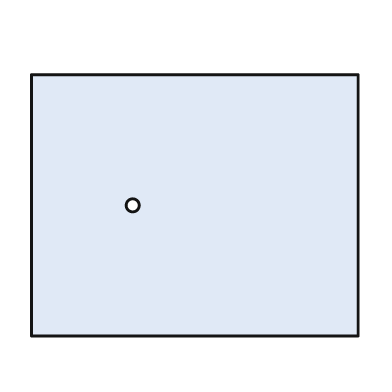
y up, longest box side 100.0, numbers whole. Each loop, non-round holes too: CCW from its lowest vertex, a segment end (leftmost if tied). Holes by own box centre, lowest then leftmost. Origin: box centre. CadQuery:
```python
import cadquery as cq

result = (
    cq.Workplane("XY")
    .moveTo(-50.0, -40.0)
    .lineTo(50.0, -40.0)
    .lineTo(50.0, 40.0)
    .lineTo(-50.0, 40.0)
    .close()
    .moveTo(-19.0, 0.0)
    .circle(2.0)
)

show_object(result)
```